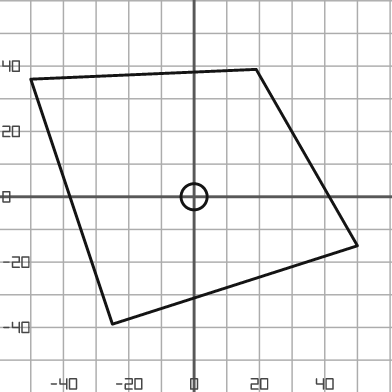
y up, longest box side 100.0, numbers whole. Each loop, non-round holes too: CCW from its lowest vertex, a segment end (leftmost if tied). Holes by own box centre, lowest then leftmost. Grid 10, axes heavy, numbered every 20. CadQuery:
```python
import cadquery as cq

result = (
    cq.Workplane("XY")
    .moveTo(-25.0, -39.0)
    .lineTo(50.0, -15.0)
    .lineTo(19.0, 39.0)
    .lineTo(-50.0, 36.0)
    .close()
    .moveTo(0.0, 0.0)
    .circle(4.0)
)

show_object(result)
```